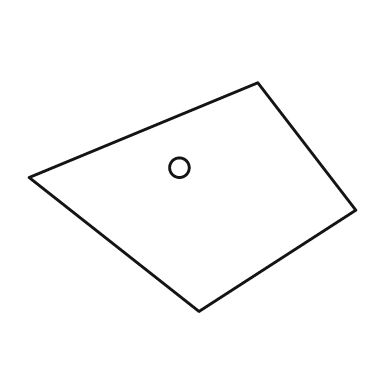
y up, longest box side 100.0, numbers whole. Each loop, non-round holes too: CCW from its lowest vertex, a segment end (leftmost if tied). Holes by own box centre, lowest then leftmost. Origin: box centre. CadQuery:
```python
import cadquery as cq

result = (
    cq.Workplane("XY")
    .moveTo(2.0, -35.0)
    .lineTo(50.0, -4.0)
    .lineTo(20.0, 35.0)
    .lineTo(-50.0, 6.0)
    .close()
    .moveTo(-4.0, 9.0)
    .circle(3.0)
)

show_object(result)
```